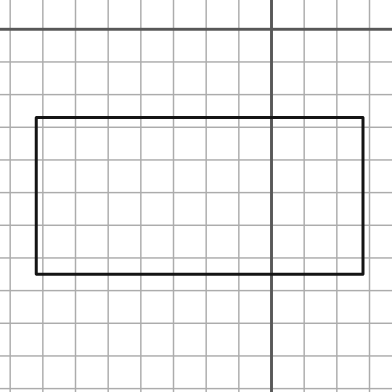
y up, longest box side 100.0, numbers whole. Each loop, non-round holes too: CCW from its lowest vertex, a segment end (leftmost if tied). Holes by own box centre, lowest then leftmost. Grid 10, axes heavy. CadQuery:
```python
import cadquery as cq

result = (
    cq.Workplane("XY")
    .moveTo(-72.0, -75.0)
    .lineTo(28.0, -75.0)
    .lineTo(28.0, -27.0)
    .lineTo(-72.0, -27.0)
    .close()
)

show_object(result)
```